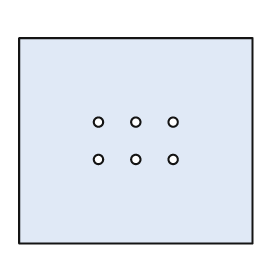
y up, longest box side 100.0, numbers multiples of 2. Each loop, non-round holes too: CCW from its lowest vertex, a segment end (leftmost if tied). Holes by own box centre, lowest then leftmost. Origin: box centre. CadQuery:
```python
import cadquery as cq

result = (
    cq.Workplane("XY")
    .moveTo(-50.0, -44.0)
    .lineTo(50.0, -44.0)
    .lineTo(50.0, 44.0)
    .lineTo(-50.0, 44.0)
    .close()
    .moveTo(-16.0, -8.0)
    .circle(2.0)
    .moveTo(0.0, -8.0)
    .circle(2.0)
    .moveTo(16.0, -8.0)
    .circle(2.0)
    .moveTo(-16.0, 8.0)
    .circle(2.0)
    .moveTo(0.0, 8.0)
    .circle(2.0)
    .moveTo(16.0, 8.0)
    .circle(2.0)
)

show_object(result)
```